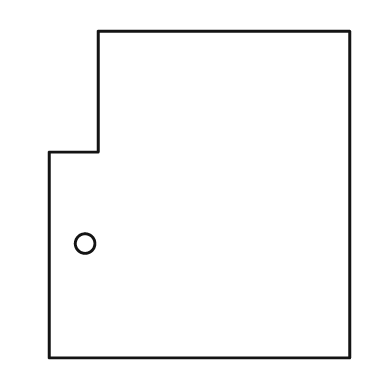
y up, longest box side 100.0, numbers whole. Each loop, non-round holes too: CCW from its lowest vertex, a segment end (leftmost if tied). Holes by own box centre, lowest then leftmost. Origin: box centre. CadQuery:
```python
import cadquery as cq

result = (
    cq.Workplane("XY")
    .moveTo(-46.0, -50.0)
    .lineTo(46.0, -50.0)
    .lineTo(46.0, 50.0)
    .lineTo(-31.0, 50.0)
    .lineTo(-31.0, 13.0)
    .lineTo(-46.0, 13.0)
    .close()
    .moveTo(-35.0, -15.0)
    .circle(3.0)
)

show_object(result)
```